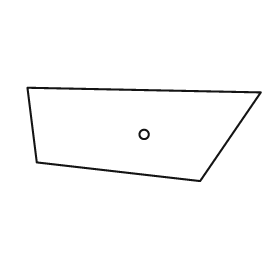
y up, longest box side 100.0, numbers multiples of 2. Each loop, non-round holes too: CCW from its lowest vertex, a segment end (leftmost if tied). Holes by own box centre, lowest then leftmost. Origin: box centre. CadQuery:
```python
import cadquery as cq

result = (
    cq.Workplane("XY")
    .moveTo(24.0, -20.0)
    .lineTo(50.0, 18.0)
    .lineTo(-50.0, 20.0)
    .lineTo(-46.0, -12.0)
    .close()
    .moveTo(0.0, 0.0)
    .circle(2.0)
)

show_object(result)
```